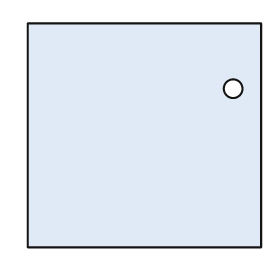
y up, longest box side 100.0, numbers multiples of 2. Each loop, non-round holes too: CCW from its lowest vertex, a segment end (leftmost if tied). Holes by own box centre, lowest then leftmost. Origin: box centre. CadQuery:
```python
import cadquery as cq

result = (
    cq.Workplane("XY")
    .moveTo(-50.0, -48.0)
    .lineTo(50.0, -48.0)
    .lineTo(50.0, 48.0)
    .lineTo(-50.0, 48.0)
    .close()
    .moveTo(38.0, 20.0)
    .circle(4.0)
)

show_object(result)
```